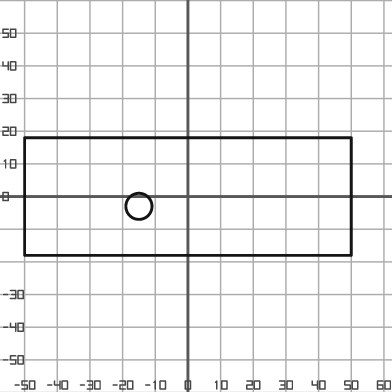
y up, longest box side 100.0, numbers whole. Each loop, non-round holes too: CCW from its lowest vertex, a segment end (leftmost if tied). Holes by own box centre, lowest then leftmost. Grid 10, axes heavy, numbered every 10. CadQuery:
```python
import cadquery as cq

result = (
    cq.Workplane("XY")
    .moveTo(-50.0, -18.0)
    .lineTo(50.0, -18.0)
    .lineTo(50.0, 18.0)
    .lineTo(-50.0, 18.0)
    .close()
    .moveTo(-15.0, -3.0)
    .circle(4.0)
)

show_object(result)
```